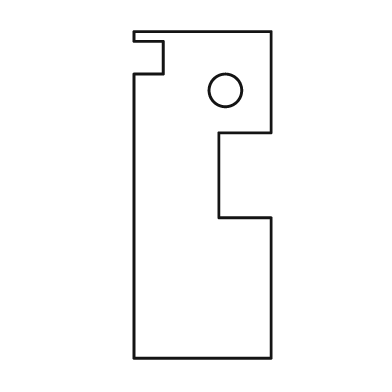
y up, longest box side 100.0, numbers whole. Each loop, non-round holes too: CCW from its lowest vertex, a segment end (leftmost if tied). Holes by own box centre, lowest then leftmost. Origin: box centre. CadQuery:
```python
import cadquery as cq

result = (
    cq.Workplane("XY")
    .moveTo(-21.0, -50.0)
    .lineTo(21.0, -50.0)
    .lineTo(21.0, -7.0)
    .lineTo(5.0, -7.0)
    .lineTo(5.0, 19.0)
    .lineTo(21.0, 19.0)
    .lineTo(21.0, 50.0)
    .lineTo(-21.0, 50.0)
    .lineTo(-21.0, 47.0)
    .lineTo(-12.0, 47.0)
    .lineTo(-12.0, 37.0)
    .lineTo(-21.0, 37.0)
    .close()
    .moveTo(7.0, 32.0)
    .circle(5.0)
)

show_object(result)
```